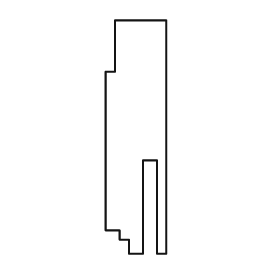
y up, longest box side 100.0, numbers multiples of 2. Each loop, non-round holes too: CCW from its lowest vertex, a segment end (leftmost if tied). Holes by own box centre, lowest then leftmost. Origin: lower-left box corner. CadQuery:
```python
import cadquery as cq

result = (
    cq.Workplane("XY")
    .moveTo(10.0, 0.0)
    .lineTo(16.0, 0.0)
    .lineTo(16.0, 40.0)
    .lineTo(22.0, 40.0)
    .lineTo(22.0, 0.0)
    .lineTo(26.0, 0.0)
    .lineTo(26.0, 100.0)
    .lineTo(4.0, 100.0)
    .lineTo(4.0, 78.0)
    .lineTo(0.0, 78.0)
    .lineTo(0.0, 10.0)
    .lineTo(6.0, 10.0)
    .lineTo(6.0, 6.0)
    .lineTo(10.0, 6.0)
    .close()
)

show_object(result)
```